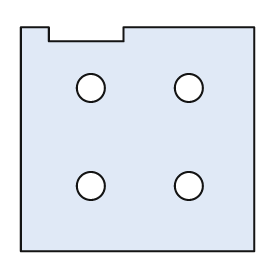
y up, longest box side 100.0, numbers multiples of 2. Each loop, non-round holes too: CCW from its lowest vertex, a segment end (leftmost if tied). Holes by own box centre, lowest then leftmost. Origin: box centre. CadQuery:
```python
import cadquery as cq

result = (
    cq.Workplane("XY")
    .moveTo(-50.0, -48.0)
    .lineTo(50.0, -48.0)
    .lineTo(50.0, 48.0)
    .lineTo(-6.0, 48.0)
    .lineTo(-6.0, 42.0)
    .lineTo(-38.0, 42.0)
    .lineTo(-38.0, 48.0)
    .lineTo(-50.0, 48.0)
    .close()
    .moveTo(-20.0, -20.0)
    .circle(6.0)
    .moveTo(22.0, -20.0)
    .circle(6.0)
    .moveTo(-20.0, 22.0)
    .circle(6.0)
    .moveTo(22.0, 22.0)
    .circle(6.0)
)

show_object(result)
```